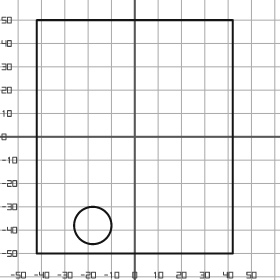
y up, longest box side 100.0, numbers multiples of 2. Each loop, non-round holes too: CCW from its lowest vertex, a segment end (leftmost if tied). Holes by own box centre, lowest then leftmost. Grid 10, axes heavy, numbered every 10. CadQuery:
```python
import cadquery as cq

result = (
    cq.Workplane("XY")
    .moveTo(-42.0, -50.0)
    .lineTo(42.0, -50.0)
    .lineTo(42.0, 50.0)
    .lineTo(-42.0, 50.0)
    .close()
    .moveTo(-18.0, -38.0)
    .circle(8.0)
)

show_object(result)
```